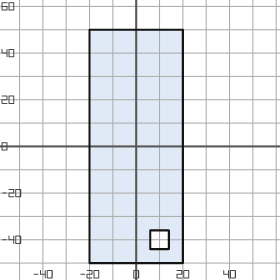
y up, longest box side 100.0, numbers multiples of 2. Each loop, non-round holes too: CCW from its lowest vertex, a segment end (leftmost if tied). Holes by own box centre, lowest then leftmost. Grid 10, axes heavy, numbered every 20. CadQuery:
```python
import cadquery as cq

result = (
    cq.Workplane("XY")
    .moveTo(-20.0, -50.0)
    .lineTo(20.0, -50.0)
    .lineTo(20.0, 50.0)
    .lineTo(-20.0, 50.0)
    .close()
    .moveTo(6.0, -44.0)
    .lineTo(14.0, -44.0)
    .lineTo(14.0, -36.0)
    .lineTo(6.0, -36.0)
    .close()
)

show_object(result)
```